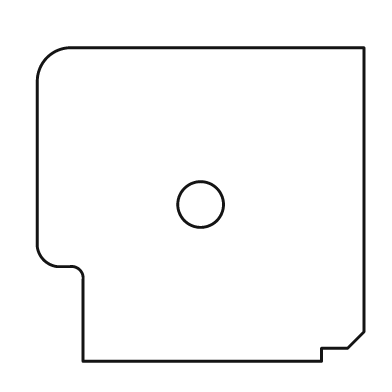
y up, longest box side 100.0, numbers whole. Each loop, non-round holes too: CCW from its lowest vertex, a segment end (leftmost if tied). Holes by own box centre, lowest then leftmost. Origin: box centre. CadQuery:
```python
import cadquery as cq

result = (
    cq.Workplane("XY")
    .moveTo(-36.0, -48.0)
    .lineTo(37.0, -48.0)
    .lineTo(37.0, -44.0)
    .lineTo(45.0, -44.0)
    .lineTo(50.0, -39.0)
    .lineTo(50.0, 48.0)
    .lineTo(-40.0, 48.0)
    .threePointArc((-47.0, 45.0), (-50.0, 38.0))
    .lineTo(-50.0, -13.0)
    .threePointArc((-48.0, -17.0), (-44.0, -19.0))
    .lineTo(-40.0, -19.0)
    .threePointArc((-37.0, -20.0), (-36.0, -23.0))
    .close()
    .moveTo(0.0, 0.0)
    .circle(7.0)
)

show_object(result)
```